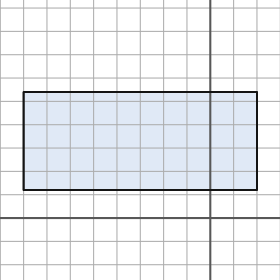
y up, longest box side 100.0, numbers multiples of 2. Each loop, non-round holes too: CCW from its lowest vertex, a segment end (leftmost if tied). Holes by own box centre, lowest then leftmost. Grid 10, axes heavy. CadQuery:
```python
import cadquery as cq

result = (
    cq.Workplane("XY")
    .moveTo(-80.0, 12.0)
    .lineTo(20.0, 12.0)
    .lineTo(20.0, 54.0)
    .lineTo(-80.0, 54.0)
    .close()
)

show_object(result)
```